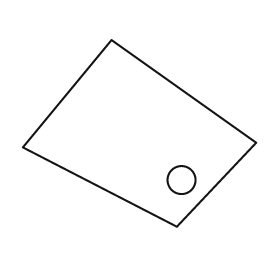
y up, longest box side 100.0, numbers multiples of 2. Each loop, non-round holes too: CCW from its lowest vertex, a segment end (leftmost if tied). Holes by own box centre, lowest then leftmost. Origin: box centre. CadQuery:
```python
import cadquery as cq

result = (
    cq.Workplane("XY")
    .moveTo(16.0, -40.0)
    .lineTo(50.0, -4.0)
    .lineTo(-12.0, 40.0)
    .lineTo(-50.0, -6.0)
    .close()
    .moveTo(18.0, -20.0)
    .circle(6.0)
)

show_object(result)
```